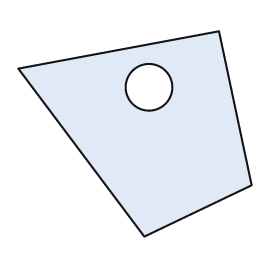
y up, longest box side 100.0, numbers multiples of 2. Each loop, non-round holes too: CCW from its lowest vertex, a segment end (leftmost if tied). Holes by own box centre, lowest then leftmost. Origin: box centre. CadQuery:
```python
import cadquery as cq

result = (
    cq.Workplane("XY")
    .moveTo(4.0, -44.0)
    .lineTo(50.0, -22.0)
    .lineTo(36.0, 44.0)
    .lineTo(-50.0, 28.0)
    .close()
    .moveTo(6.0, 20.0)
    .circle(10.0)
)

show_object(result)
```